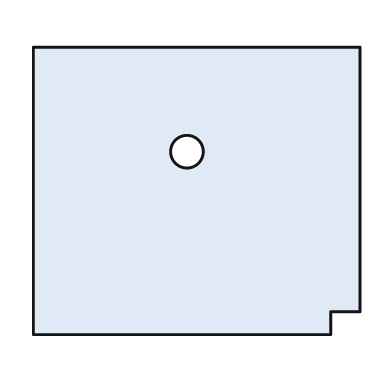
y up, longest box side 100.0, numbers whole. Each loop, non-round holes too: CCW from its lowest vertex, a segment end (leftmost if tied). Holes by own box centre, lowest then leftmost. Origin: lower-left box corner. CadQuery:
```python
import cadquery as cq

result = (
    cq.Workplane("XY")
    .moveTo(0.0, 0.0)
    .lineTo(91.0, 0.0)
    .lineTo(91.0, 7.0)
    .lineTo(100.0, 7.0)
    .lineTo(100.0, 88.0)
    .lineTo(0.0, 88.0)
    .close()
    .moveTo(47.0, 56.0)
    .circle(5.0)
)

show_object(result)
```